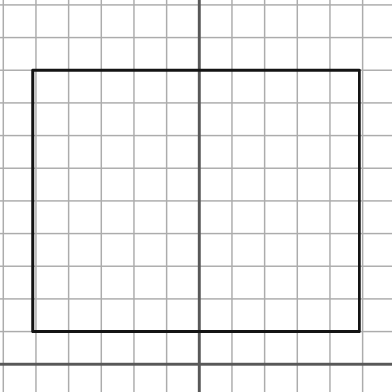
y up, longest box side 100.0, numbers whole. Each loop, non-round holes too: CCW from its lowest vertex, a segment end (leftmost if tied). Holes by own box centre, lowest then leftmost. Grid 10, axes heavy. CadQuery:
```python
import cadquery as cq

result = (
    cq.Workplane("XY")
    .moveTo(-51.0, 10.0)
    .lineTo(49.0, 10.0)
    .lineTo(49.0, 90.0)
    .lineTo(-51.0, 90.0)
    .close()
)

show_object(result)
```